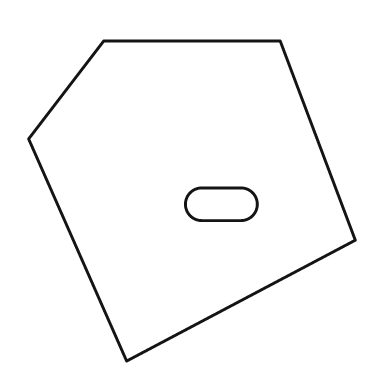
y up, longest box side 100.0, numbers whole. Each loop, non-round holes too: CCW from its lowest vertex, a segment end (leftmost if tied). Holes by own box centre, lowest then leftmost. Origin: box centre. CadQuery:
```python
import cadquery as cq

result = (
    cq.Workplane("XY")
    .moveTo(-20.0, -49.0)
    .lineTo(50.0, -12.0)
    .lineTo(27.0, 49.0)
    .lineTo(-27.0, 49.0)
    .lineTo(-50.0, 19.0)
    .close()
    .moveTo(3.0, -6.0)
    .lineTo(15.0, -6.0)
    .threePointArc((20.0, -1.0), (15.0, 4.0))
    .lineTo(3.0, 4.0)
    .threePointArc((-2.0, -1.0), (3.0, -6.0))
    .close()
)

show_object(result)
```